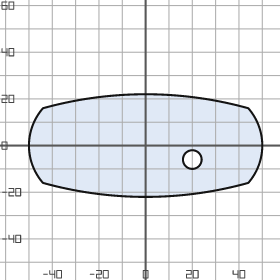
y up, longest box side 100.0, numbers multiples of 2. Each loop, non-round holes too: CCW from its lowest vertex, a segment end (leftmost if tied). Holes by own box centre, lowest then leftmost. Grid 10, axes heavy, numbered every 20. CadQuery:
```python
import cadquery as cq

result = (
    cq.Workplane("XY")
    .moveTo(-44.0, -16.0)
    .threePointArc((0.0, -22.0), (44.0, -16.0))
    .threePointArc((50.0, 0.0), (44.0, 16.0))
    .threePointArc((0.0, 22.0), (-44.0, 16.0))
    .threePointArc((-50.0, 0.0), (-44.0, -16.0))
    .close()
    .moveTo(20.0, -6.0)
    .circle(4.0)
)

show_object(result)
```